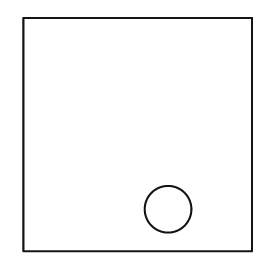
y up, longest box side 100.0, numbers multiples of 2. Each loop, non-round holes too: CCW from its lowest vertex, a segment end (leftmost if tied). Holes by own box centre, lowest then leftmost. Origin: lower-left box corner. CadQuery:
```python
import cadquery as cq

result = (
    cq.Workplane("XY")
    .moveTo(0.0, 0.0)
    .lineTo(98.0, 0.0)
    .lineTo(98.0, 100.0)
    .lineTo(0.0, 100.0)
    .close()
    .moveTo(62.0, 18.0)
    .circle(10.0)
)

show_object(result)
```